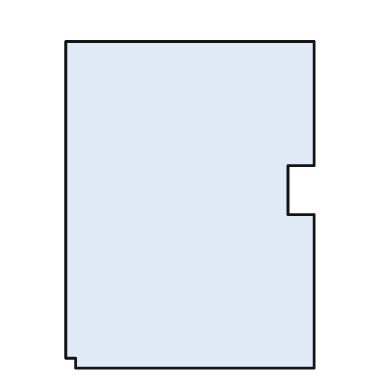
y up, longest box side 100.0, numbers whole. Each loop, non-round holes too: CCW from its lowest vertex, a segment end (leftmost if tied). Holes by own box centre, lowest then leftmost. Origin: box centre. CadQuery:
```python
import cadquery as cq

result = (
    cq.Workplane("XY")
    .moveTo(-35.0, -50.0)
    .lineTo(38.0, -50.0)
    .lineTo(38.0, -3.0)
    .lineTo(30.0, -3.0)
    .lineTo(30.0, 12.0)
    .lineTo(38.0, 12.0)
    .lineTo(38.0, 50.0)
    .lineTo(-38.0, 50.0)
    .lineTo(-38.0, -47.0)
    .lineTo(-35.0, -47.0)
    .close()
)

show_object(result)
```